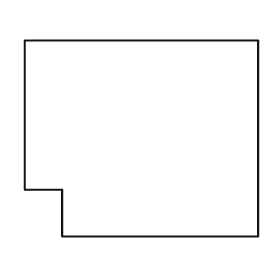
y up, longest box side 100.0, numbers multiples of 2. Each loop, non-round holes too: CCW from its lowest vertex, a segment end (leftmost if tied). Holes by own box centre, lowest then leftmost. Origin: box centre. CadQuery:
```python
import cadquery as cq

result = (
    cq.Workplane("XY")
    .moveTo(-34.0, -42.0)
    .lineTo(50.0, -42.0)
    .lineTo(50.0, 42.0)
    .lineTo(-50.0, 42.0)
    .lineTo(-50.0, -22.0)
    .lineTo(-34.0, -22.0)
    .close()
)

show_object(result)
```